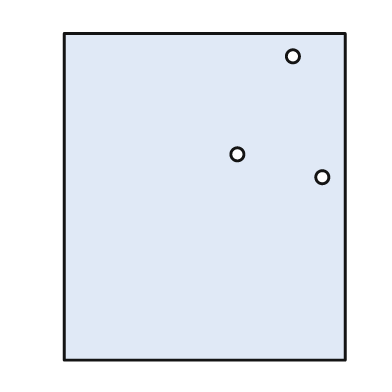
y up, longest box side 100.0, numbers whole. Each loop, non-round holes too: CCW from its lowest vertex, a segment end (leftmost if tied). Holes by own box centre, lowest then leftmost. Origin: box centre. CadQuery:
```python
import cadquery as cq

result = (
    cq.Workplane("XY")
    .moveTo(-43.0, -50.0)
    .lineTo(43.0, -50.0)
    .lineTo(43.0, 50.0)
    .lineTo(-43.0, 50.0)
    .close()
    .moveTo(36.0, 6.0)
    .circle(2.0)
    .moveTo(10.0, 13.0)
    .circle(2.0)
    .moveTo(27.0, 43.0)
    .circle(2.0)
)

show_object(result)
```